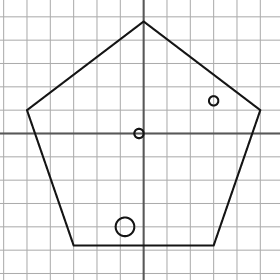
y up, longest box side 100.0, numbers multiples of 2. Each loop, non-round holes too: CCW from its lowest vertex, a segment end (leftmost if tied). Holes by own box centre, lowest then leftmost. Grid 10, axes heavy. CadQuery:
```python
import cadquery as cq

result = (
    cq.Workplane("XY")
    .moveTo(-30.0, -48.0)
    .lineTo(30.0, -48.0)
    .lineTo(50.0, 10.0)
    .lineTo(0.0, 48.0)
    .lineTo(-50.0, 10.0)
    .close()
    .moveTo(-8.0, -40.0)
    .circle(4.0)
    .moveTo(-2.0, 0.0)
    .circle(2.0)
    .moveTo(30.0, 14.0)
    .circle(2.0)
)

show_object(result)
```